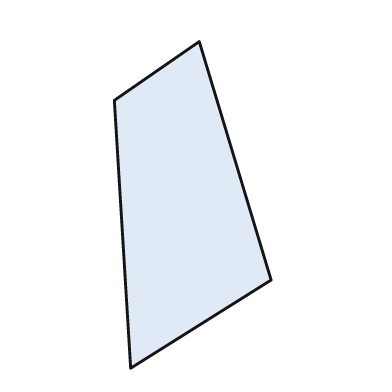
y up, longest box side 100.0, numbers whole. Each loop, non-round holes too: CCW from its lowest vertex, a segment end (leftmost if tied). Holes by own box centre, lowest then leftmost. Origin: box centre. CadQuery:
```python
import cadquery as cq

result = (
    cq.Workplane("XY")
    .moveTo(-19.0, -50.0)
    .lineTo(24.0, -23.0)
    .lineTo(2.0, 50.0)
    .lineTo(-24.0, 32.0)
    .close()
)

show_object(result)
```